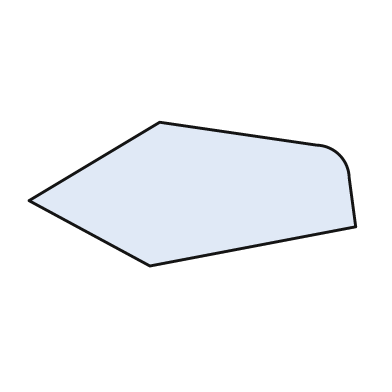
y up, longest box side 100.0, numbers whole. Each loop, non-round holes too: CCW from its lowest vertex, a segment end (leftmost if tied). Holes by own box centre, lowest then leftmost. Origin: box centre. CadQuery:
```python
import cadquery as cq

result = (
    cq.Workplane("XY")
    .moveTo(-13.0, -22.0)
    .lineTo(50.0, -10.0)
    .lineTo(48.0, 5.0)
    .threePointArc((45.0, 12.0), (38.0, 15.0))
    .lineTo(-10.0, 22.0)
    .lineTo(-50.0, -2.0)
    .close()
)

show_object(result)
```